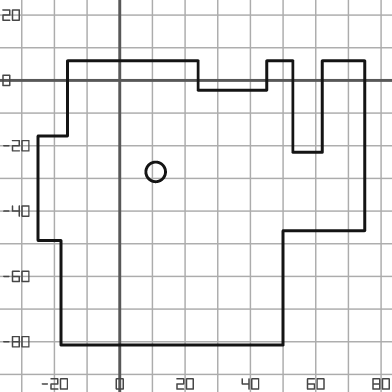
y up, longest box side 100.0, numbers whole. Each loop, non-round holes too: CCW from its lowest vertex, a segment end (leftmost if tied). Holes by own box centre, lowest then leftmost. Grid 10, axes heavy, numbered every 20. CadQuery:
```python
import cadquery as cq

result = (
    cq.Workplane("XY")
    .moveTo(-18.0, -81.0)
    .lineTo(50.0, -81.0)
    .lineTo(50.0, -46.0)
    .lineTo(75.0, -46.0)
    .lineTo(75.0, 6.0)
    .lineTo(62.0, 6.0)
    .lineTo(62.0, -22.0)
    .lineTo(53.0, -22.0)
    .lineTo(53.0, 6.0)
    .lineTo(45.0, 6.0)
    .lineTo(45.0, -3.0)
    .lineTo(24.0, -3.0)
    .lineTo(24.0, 6.0)
    .lineTo(-16.0, 6.0)
    .lineTo(-16.0, -17.0)
    .lineTo(-25.0, -17.0)
    .lineTo(-25.0, -49.0)
    .lineTo(-18.0, -49.0)
    .close()
    .moveTo(11.0, -28.0)
    .circle(3.0)
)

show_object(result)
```